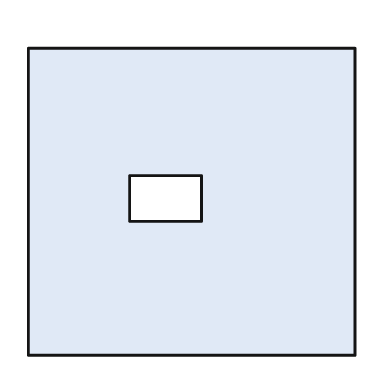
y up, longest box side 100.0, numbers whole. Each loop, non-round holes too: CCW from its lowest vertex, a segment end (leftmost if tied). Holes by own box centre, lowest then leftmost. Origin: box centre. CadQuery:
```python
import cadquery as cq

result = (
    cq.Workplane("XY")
    .moveTo(-50.0, -47.0)
    .lineTo(50.0, -47.0)
    .lineTo(50.0, 47.0)
    .lineTo(-50.0, 47.0)
    .close()
    .moveTo(-19.0, -6.0)
    .lineTo(3.0, -6.0)
    .lineTo(3.0, 8.0)
    .lineTo(-19.0, 8.0)
    .close()
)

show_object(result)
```